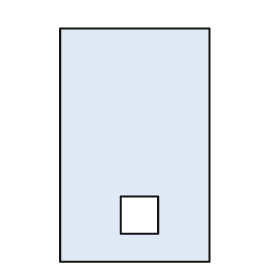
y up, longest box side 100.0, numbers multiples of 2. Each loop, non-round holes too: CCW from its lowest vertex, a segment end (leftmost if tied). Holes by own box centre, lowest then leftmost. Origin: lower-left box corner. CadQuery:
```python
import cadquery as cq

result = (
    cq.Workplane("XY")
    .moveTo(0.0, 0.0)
    .lineTo(64.0, 0.0)
    .lineTo(64.0, 100.0)
    .lineTo(0.0, 100.0)
    .close()
    .moveTo(26.0, 12.0)
    .lineTo(42.0, 12.0)
    .lineTo(42.0, 28.0)
    .lineTo(26.0, 28.0)
    .close()
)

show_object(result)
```